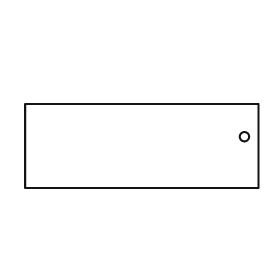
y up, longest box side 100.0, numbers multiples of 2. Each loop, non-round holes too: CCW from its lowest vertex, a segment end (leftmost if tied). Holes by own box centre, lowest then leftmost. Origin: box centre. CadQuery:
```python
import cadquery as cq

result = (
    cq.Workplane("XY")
    .moveTo(-50.0, -18.0)
    .lineTo(50.0, -18.0)
    .lineTo(50.0, 18.0)
    .lineTo(-50.0, 18.0)
    .close()
    .moveTo(44.0, 4.0)
    .circle(2.0)
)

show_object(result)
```